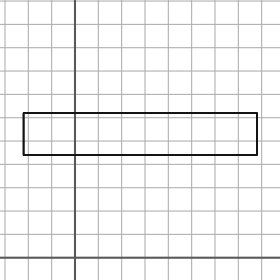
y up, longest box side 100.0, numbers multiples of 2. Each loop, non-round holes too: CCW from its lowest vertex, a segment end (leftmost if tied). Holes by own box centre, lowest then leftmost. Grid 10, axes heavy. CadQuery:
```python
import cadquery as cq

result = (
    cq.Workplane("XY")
    .moveTo(-22.0, 44.0)
    .lineTo(78.0, 44.0)
    .lineTo(78.0, 62.0)
    .lineTo(-22.0, 62.0)
    .close()
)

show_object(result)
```